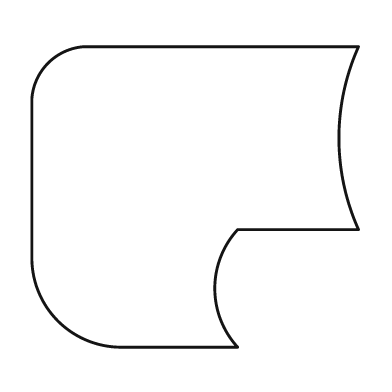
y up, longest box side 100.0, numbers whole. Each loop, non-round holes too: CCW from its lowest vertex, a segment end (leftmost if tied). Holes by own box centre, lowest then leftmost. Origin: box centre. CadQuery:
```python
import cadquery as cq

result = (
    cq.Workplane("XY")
    .moveTo(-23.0, -46.0)
    .lineTo(13.0, -46.0)
    .threePointArc((6.0, -28.0), (13.0, -10.0))
    .lineTo(50.0, -10.0)
    .threePointArc((44.0, 18.0), (50.0, 46.0))
    .lineTo(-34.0, 46.0)
    .threePointArc((-45.0, 41.0), (-50.0, 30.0))
    .lineTo(-50.0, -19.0)
    .threePointArc((-42.0, -38.0), (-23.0, -46.0))
    .close()
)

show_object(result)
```